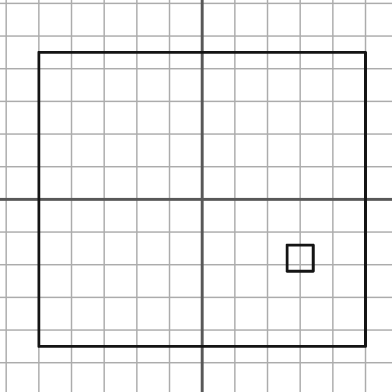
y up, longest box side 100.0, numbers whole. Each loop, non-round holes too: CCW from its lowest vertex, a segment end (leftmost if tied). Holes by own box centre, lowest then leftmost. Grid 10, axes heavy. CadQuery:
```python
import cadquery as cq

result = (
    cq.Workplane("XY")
    .moveTo(-50.0, -45.0)
    .lineTo(50.0, -45.0)
    .lineTo(50.0, 45.0)
    .lineTo(-50.0, 45.0)
    .close()
    .moveTo(26.0, -22.0)
    .lineTo(34.0, -22.0)
    .lineTo(34.0, -14.0)
    .lineTo(26.0, -14.0)
    .close()
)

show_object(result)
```